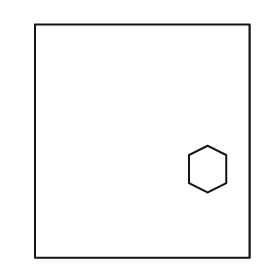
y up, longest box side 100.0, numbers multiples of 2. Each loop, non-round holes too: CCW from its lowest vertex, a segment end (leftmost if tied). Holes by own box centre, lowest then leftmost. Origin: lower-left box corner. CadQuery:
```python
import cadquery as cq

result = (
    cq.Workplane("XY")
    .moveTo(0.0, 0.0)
    .lineTo(92.0, 0.0)
    .lineTo(92.0, 100.0)
    .lineTo(0.0, 100.0)
    .close()
    .moveTo(74.0, 28.0)
    .lineTo(82.0, 32.0)
    .lineTo(82.0, 44.0)
    .lineTo(74.0, 48.0)
    .lineTo(66.0, 44.0)
    .lineTo(66.0, 32.0)
    .close()
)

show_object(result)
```